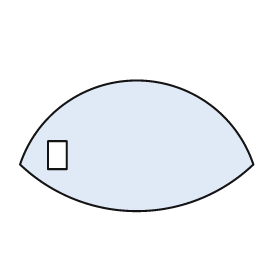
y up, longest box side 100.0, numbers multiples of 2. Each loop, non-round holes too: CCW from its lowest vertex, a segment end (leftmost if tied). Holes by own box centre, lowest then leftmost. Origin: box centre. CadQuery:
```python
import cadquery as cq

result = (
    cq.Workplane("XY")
    .moveTo(-50.0, -8.0)
    .threePointArc((0.0, -28.0), (50.0, -8.0))
    .threePointArc((0.0, 28.0), (-50.0, -8.0))
    .close()
    .moveTo(-38.0, -10.0)
    .lineTo(-30.0, -10.0)
    .lineTo(-30.0, 2.0)
    .lineTo(-38.0, 2.0)
    .close()
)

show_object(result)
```